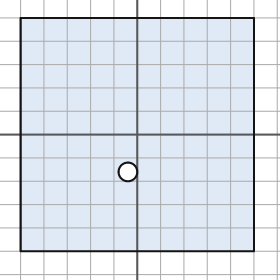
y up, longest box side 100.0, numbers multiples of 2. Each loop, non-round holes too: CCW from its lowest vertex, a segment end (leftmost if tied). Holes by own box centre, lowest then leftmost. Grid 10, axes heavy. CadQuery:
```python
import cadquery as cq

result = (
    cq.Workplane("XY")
    .moveTo(-50.0, -50.0)
    .lineTo(50.0, -50.0)
    .lineTo(50.0, 50.0)
    .lineTo(-50.0, 50.0)
    .close()
    .moveTo(-4.0, -16.0)
    .circle(4.0)
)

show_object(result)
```